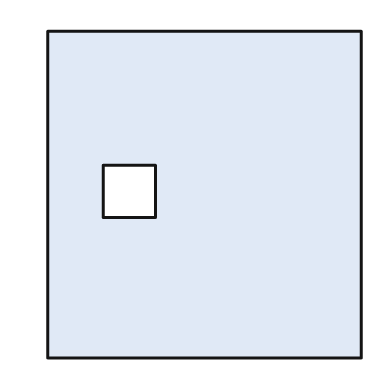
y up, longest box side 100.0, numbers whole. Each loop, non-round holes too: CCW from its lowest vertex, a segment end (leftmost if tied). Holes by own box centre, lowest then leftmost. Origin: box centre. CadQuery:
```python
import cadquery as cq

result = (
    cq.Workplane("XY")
    .moveTo(-48.0, -50.0)
    .lineTo(48.0, -50.0)
    .lineTo(48.0, 50.0)
    .lineTo(-48.0, 50.0)
    .close()
    .moveTo(-31.0, -7.0)
    .lineTo(-15.0, -7.0)
    .lineTo(-15.0, 9.0)
    .lineTo(-31.0, 9.0)
    .close()
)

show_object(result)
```